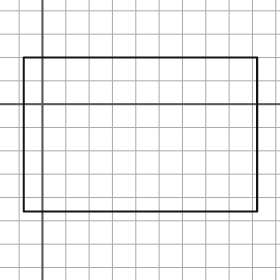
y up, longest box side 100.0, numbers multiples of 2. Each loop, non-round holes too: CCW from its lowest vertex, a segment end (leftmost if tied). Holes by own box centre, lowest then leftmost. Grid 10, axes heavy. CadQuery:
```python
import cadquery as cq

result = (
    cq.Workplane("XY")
    .moveTo(-8.0, -46.0)
    .lineTo(92.0, -46.0)
    .lineTo(92.0, 20.0)
    .lineTo(-8.0, 20.0)
    .close()
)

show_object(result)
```